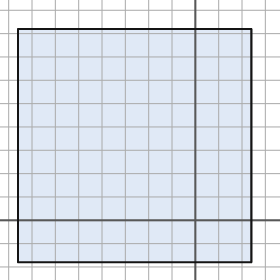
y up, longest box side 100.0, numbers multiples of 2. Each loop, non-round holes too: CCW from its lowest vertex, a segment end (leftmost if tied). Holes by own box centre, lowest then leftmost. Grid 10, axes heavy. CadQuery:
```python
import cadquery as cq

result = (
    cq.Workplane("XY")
    .moveTo(-76.0, -18.0)
    .lineTo(24.0, -18.0)
    .lineTo(24.0, 82.0)
    .lineTo(-76.0, 82.0)
    .close()
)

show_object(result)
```